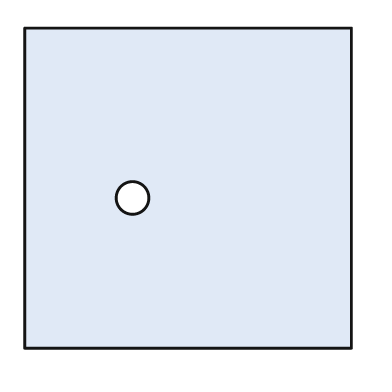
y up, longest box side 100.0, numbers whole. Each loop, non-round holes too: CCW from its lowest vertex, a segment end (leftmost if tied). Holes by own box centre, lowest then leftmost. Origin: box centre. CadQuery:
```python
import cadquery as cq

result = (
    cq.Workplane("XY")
    .moveTo(-50.0, -49.0)
    .lineTo(50.0, -49.0)
    .lineTo(50.0, 49.0)
    .lineTo(-50.0, 49.0)
    .close()
    .moveTo(-17.0, -3.0)
    .circle(5.0)
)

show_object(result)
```